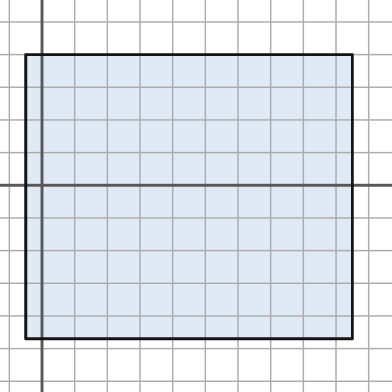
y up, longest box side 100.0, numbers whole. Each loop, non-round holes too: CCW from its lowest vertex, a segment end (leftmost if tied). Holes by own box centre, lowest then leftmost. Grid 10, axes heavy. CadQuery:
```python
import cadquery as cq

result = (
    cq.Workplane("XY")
    .moveTo(-5.0, -47.0)
    .lineTo(95.0, -47.0)
    .lineTo(95.0, 40.0)
    .lineTo(-5.0, 40.0)
    .close()
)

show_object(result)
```